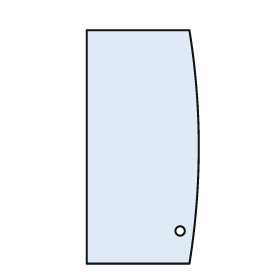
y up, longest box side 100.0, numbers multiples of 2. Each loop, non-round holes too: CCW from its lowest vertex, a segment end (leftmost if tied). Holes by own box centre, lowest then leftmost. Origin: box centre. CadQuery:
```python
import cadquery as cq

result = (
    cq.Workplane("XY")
    .moveTo(-24.0, -50.0)
    .lineTo(20.0, -50.0)
    .threePointArc((24.0, 0.0), (20.0, 50.0))
    .lineTo(-24.0, 50.0)
    .close()
    .moveTo(16.0, -36.0)
    .circle(2.0)
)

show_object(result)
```